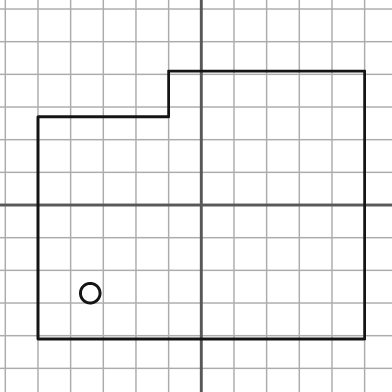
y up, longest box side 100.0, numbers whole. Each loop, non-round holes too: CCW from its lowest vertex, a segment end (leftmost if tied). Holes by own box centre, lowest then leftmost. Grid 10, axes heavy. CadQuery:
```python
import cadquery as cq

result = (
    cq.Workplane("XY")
    .moveTo(-50.0, -41.0)
    .lineTo(50.0, -41.0)
    .lineTo(50.0, 41.0)
    .lineTo(-10.0, 41.0)
    .lineTo(-10.0, 27.0)
    .lineTo(-50.0, 27.0)
    .close()
    .moveTo(-34.0, -27.0)
    .circle(3.0)
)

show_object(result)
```